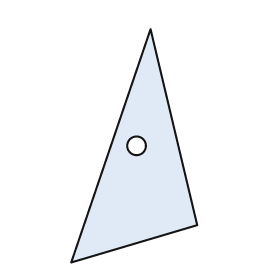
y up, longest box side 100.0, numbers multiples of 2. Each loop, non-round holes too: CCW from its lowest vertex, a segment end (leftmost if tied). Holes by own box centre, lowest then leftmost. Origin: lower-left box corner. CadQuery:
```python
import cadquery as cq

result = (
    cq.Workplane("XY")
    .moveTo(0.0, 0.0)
    .lineTo(54.0, 16.0)
    .lineTo(34.0, 100.0)
    .close()
    .moveTo(28.0, 50.0)
    .circle(4.0)
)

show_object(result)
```